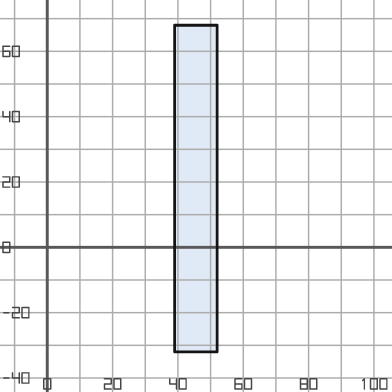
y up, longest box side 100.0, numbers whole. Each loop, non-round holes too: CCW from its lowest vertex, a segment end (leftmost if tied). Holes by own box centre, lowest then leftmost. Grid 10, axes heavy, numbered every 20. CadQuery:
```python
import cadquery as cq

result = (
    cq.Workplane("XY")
    .moveTo(39.0, -32.0)
    .lineTo(52.0, -32.0)
    .lineTo(52.0, 68.0)
    .lineTo(39.0, 68.0)
    .close()
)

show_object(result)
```